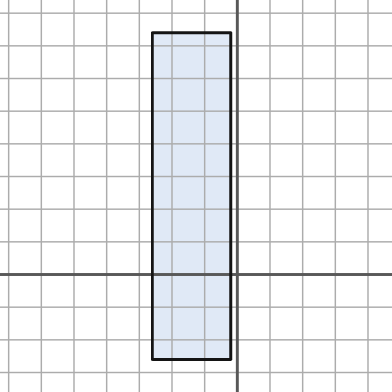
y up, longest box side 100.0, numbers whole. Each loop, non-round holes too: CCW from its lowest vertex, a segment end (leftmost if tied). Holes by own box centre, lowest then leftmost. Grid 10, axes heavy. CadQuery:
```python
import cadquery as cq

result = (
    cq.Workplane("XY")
    .moveTo(-26.0, -26.0)
    .lineTo(-2.0, -26.0)
    .lineTo(-2.0, 74.0)
    .lineTo(-26.0, 74.0)
    .close()
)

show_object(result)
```